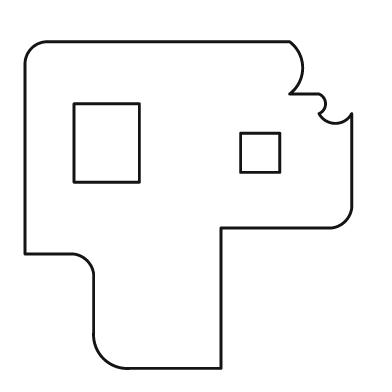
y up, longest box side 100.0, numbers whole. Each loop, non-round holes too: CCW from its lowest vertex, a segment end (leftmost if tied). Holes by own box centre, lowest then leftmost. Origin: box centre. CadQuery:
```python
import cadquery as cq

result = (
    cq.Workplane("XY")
    .moveTo(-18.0, -50.0)
    .lineTo(10.0, -50.0)
    .lineTo(10.0, -7.0)
    .lineTo(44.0, -7.0)
    .threePointArc((48.0, -5.0), (50.0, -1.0))
    .lineTo(50.0, 28.0)
    .threePointArc((45.0, 25.0), (40.0, 28.0))
    .threePointArc((42.0, 31.0), (40.0, 34.0))
    .lineTo(31.0, 34.0)
    .threePointArc((35.0, 42.0), (31.0, 50.0))
    .lineTo(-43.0, 50.0)
    .threePointArc((-48.0, 48.0), (-50.0, 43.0))
    .lineTo(-50.0, -15.0)
    .lineTo(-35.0, -15.0)
    .threePointArc((-31.0, -17.0), (-29.0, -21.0))
    .lineTo(-29.0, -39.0)
    .threePointArc((-26.0, -47.0), (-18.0, -50.0))
    .close()
    .moveTo(16.0, 10.0)
    .lineTo(28.0, 10.0)
    .lineTo(28.0, 22.0)
    .lineTo(16.0, 22.0)
    .close()
    .moveTo(-35.0, 7.0)
    .lineTo(-15.0, 7.0)
    .lineTo(-15.0, 31.0)
    .lineTo(-35.0, 31.0)
    .close()
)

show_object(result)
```